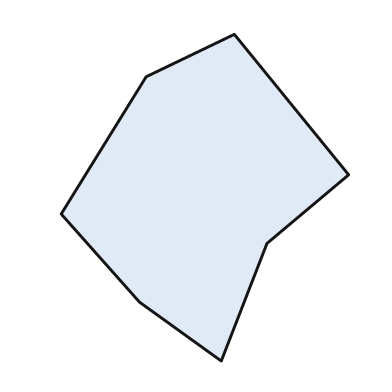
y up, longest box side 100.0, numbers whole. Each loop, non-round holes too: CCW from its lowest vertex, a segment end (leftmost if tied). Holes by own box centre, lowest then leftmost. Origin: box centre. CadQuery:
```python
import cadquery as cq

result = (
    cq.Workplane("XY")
    .moveTo(5.0, -50.0)
    .lineTo(19.0, -14.0)
    .lineTo(44.0, 7.0)
    .lineTo(9.0, 50.0)
    .lineTo(-18.0, 37.0)
    .lineTo(-44.0, -5.0)
    .lineTo(-20.0, -32.0)
    .close()
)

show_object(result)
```